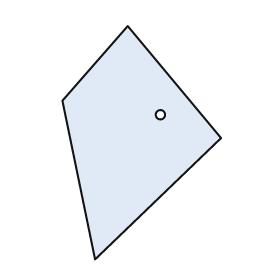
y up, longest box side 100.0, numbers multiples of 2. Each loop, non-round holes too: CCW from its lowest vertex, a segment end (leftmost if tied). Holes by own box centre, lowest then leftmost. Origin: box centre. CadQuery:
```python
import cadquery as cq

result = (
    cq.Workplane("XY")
    .moveTo(-20.0, -50.0)
    .lineTo(34.0, 2.0)
    .lineTo(-6.0, 50.0)
    .lineTo(-34.0, 18.0)
    .close()
    .moveTo(8.0, 12.0)
    .circle(2.0)
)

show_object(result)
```